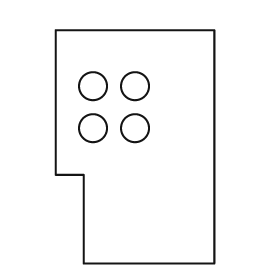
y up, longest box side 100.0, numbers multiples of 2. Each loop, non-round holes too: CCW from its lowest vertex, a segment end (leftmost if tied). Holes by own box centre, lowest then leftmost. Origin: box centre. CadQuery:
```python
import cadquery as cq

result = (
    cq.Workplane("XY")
    .moveTo(-22.0, -50.0)
    .lineTo(34.0, -50.0)
    .lineTo(34.0, 50.0)
    .lineTo(-34.0, 50.0)
    .lineTo(-34.0, -12.0)
    .lineTo(-22.0, -12.0)
    .close()
    .moveTo(-18.0, 8.0)
    .circle(6.0)
    .moveTo(0.0, 8.0)
    .circle(6.0)
    .moveTo(-18.0, 26.0)
    .circle(6.0)
    .moveTo(0.0, 26.0)
    .circle(6.0)
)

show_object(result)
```